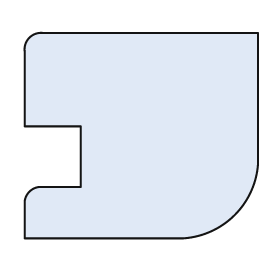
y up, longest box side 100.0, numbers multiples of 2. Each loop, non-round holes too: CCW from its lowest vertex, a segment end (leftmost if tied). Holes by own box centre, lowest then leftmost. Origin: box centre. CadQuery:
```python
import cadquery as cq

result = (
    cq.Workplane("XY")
    .moveTo(-50.0, -44.0)
    .lineTo(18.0, -44.0)
    .threePointArc((40.0, -34.0), (50.0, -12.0))
    .lineTo(50.0, 44.0)
    .lineTo(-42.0, 44.0)
    .threePointArc((-48.0, 42.0), (-50.0, 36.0))
    .lineTo(-50.0, 4.0)
    .lineTo(-26.0, 4.0)
    .lineTo(-26.0, -22.0)
    .lineTo(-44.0, -22.0)
    .threePointArc((-48.0, -24.0), (-50.0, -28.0))
    .close()
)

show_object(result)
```